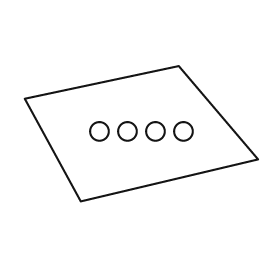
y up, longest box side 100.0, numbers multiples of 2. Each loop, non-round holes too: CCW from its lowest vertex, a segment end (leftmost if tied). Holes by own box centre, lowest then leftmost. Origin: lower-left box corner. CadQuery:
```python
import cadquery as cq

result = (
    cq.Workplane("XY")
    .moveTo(24.0, 0.0)
    .lineTo(100.0, 18.0)
    .lineTo(66.0, 58.0)
    .lineTo(0.0, 44.0)
    .close()
    .moveTo(32.0, 30.0)
    .circle(4.0)
    .moveTo(44.0, 30.0)
    .circle(4.0)
    .moveTo(56.0, 30.0)
    .circle(4.0)
    .moveTo(68.0, 30.0)
    .circle(4.0)
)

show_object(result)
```